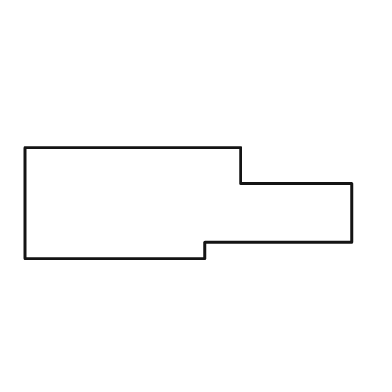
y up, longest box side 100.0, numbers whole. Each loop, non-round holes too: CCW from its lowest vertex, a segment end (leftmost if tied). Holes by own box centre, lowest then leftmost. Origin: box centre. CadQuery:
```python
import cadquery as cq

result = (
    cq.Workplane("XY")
    .moveTo(-50.0, -17.0)
    .lineTo(5.0, -17.0)
    .lineTo(5.0, -12.0)
    .lineTo(50.0, -12.0)
    .lineTo(50.0, 6.0)
    .lineTo(16.0, 6.0)
    .lineTo(16.0, 17.0)
    .lineTo(-50.0, 17.0)
    .close()
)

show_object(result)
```